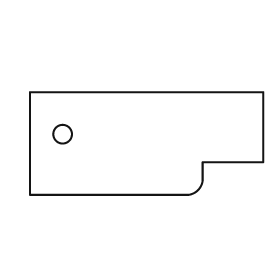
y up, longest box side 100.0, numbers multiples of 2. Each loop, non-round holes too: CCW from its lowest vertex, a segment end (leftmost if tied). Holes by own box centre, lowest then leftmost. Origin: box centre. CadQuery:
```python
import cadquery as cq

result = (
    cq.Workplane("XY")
    .moveTo(-50.0, -22.0)
    .lineTo(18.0, -22.0)
    .threePointArc((22.0, -20.0), (24.0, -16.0))
    .lineTo(24.0, -8.0)
    .lineTo(50.0, -8.0)
    .lineTo(50.0, 22.0)
    .lineTo(-50.0, 22.0)
    .close()
    .moveTo(-36.0, 4.0)
    .circle(4.0)
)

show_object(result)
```